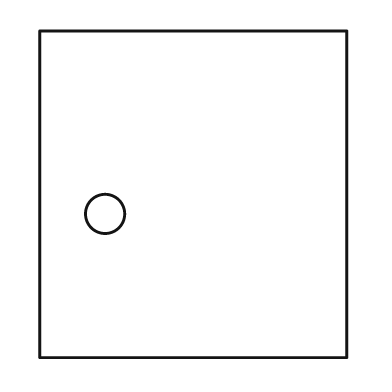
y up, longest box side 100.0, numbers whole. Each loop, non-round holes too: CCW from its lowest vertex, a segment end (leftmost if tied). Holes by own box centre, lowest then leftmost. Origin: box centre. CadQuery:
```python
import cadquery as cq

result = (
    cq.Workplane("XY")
    .moveTo(-47.0, -50.0)
    .lineTo(47.0, -50.0)
    .lineTo(47.0, 50.0)
    .lineTo(-47.0, 50.0)
    .close()
    .moveTo(-27.0, -6.0)
    .circle(6.0)
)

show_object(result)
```